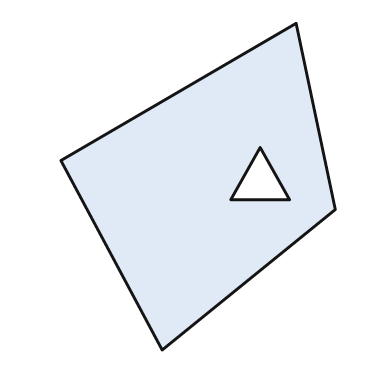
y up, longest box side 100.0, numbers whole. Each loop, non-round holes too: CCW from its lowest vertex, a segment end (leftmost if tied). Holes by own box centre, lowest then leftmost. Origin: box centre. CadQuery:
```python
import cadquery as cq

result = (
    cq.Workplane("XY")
    .moveTo(-11.0, -50.0)
    .lineTo(42.0, -7.0)
    .lineTo(30.0, 50.0)
    .lineTo(-42.0, 8.0)
    .close()
    .moveTo(10.0, -4.0)
    .lineTo(28.0, -4.0)
    .lineTo(19.0, 12.0)
    .close()
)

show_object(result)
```